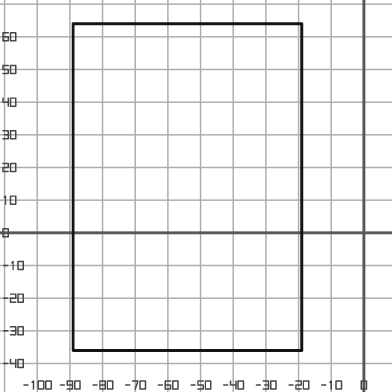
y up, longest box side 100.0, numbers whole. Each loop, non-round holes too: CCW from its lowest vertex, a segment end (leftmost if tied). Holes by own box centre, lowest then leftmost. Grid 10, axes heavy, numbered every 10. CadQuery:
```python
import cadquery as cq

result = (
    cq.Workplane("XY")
    .moveTo(-89.0, -36.0)
    .lineTo(-19.0, -36.0)
    .lineTo(-19.0, 64.0)
    .lineTo(-89.0, 64.0)
    .close()
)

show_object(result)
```